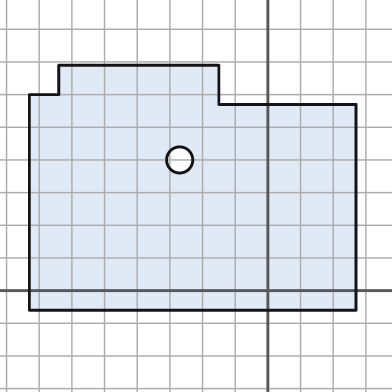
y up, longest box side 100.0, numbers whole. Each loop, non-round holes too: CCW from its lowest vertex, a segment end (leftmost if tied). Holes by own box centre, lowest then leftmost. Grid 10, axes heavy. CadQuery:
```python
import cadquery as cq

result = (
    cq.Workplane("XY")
    .moveTo(-73.0, -6.0)
    .lineTo(27.0, -6.0)
    .lineTo(27.0, 57.0)
    .lineTo(-15.0, 57.0)
    .lineTo(-15.0, 69.0)
    .lineTo(-64.0, 69.0)
    .lineTo(-64.0, 60.0)
    .lineTo(-73.0, 60.0)
    .close()
    .moveTo(-27.0, 40.0)
    .circle(4.0)
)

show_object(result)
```